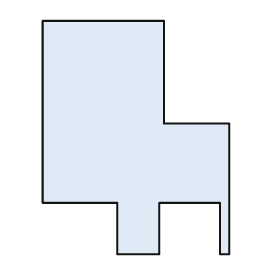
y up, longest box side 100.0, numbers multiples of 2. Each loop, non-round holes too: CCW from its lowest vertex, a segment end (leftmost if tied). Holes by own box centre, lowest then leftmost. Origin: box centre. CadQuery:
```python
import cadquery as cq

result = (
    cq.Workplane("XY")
    .moveTo(-8.0, -50.0)
    .lineTo(10.0, -50.0)
    .lineTo(10.0, -28.0)
    .lineTo(36.0, -28.0)
    .lineTo(36.0, -50.0)
    .lineTo(40.0, -50.0)
    .lineTo(40.0, 6.0)
    .lineTo(12.0, 6.0)
    .lineTo(12.0, 50.0)
    .lineTo(-40.0, 50.0)
    .lineTo(-40.0, -28.0)
    .lineTo(-8.0, -28.0)
    .close()
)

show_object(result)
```